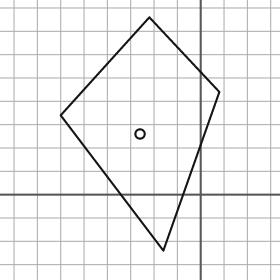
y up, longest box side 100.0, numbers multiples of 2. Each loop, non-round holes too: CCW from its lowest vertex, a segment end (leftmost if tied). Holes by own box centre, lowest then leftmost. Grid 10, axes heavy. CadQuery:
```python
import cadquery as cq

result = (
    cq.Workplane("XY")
    .moveTo(-16.0, -24.0)
    .lineTo(8.0, 44.0)
    .lineTo(-22.0, 76.0)
    .lineTo(-60.0, 34.0)
    .close()
    .moveTo(-26.0, 26.0)
    .circle(2.0)
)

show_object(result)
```